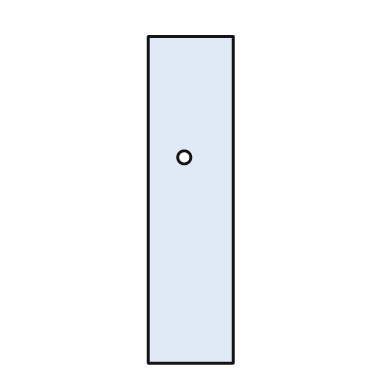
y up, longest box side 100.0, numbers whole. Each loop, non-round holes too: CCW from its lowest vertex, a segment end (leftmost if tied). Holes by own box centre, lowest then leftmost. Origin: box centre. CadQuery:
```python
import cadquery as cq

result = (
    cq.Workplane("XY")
    .moveTo(-13.0, -50.0)
    .lineTo(13.0, -50.0)
    .lineTo(13.0, 50.0)
    .lineTo(-13.0, 50.0)
    .close()
    .moveTo(-2.0, 13.0)
    .circle(2.0)
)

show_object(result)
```